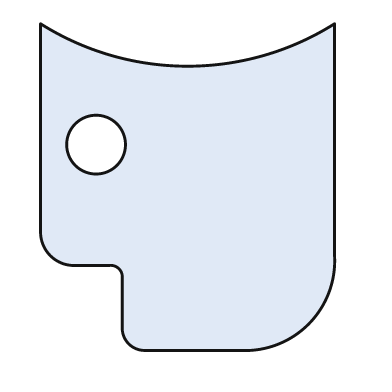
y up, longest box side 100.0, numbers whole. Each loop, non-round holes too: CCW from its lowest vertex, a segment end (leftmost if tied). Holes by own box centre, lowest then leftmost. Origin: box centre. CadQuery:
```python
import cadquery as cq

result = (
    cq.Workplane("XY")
    .moveTo(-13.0, -50.0)
    .lineTo(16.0, -50.0)
    .threePointArc((37.0, -42.0), (45.0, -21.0))
    .lineTo(45.0, 50.0)
    .threePointArc((0.0, 37.0), (-45.0, 50.0))
    .lineTo(-45.0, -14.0)
    .threePointArc((-42.0, -21.0), (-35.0, -24.0))
    .lineTo(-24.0, -24.0)
    .threePointArc((-21.0, -25.0), (-20.0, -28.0))
    .lineTo(-20.0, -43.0)
    .threePointArc((-18.0, -48.0), (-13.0, -50.0))
    .close()
    .moveTo(-28.0, 13.0)
    .circle(9.0)
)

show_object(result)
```